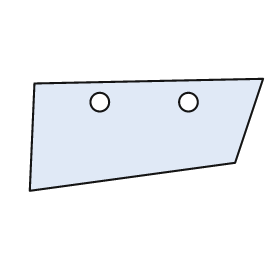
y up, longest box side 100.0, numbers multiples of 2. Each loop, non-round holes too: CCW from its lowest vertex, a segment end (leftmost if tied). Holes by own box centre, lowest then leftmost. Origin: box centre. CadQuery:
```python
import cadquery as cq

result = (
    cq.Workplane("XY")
    .moveTo(-50.0, -24.0)
    .lineTo(38.0, -12.0)
    .lineTo(50.0, 24.0)
    .lineTo(-48.0, 22.0)
    .close()
    .moveTo(-20.0, 14.0)
    .circle(4.0)
    .moveTo(18.0, 14.0)
    .circle(4.0)
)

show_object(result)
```